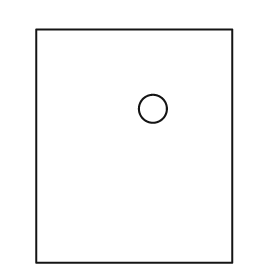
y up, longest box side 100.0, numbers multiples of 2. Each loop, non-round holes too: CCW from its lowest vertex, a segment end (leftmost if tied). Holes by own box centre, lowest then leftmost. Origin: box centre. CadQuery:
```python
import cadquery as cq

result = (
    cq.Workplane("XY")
    .moveTo(-42.0, -50.0)
    .lineTo(42.0, -50.0)
    .lineTo(42.0, 50.0)
    .lineTo(-42.0, 50.0)
    .close()
    .moveTo(8.0, 16.0)
    .circle(6.0)
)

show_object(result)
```